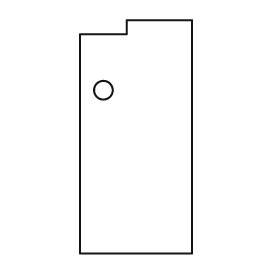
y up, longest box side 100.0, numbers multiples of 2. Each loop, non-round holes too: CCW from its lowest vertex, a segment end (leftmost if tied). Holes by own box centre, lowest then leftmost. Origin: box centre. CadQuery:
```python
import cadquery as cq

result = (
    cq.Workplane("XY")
    .moveTo(-24.0, -50.0)
    .lineTo(24.0, -50.0)
    .lineTo(24.0, 50.0)
    .lineTo(-4.0, 50.0)
    .lineTo(-4.0, 44.0)
    .lineTo(-24.0, 44.0)
    .close()
    .moveTo(-14.0, 20.0)
    .circle(4.0)
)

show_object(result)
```